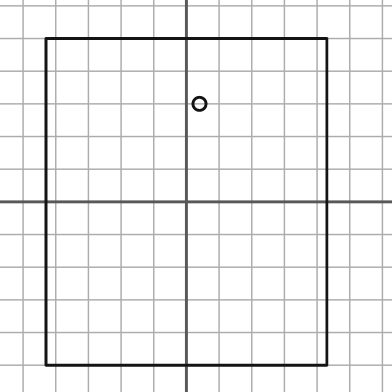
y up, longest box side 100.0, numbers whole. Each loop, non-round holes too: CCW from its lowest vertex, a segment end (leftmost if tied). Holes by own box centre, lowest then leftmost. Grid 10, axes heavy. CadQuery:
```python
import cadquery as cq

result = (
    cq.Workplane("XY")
    .moveTo(-43.0, -50.0)
    .lineTo(43.0, -50.0)
    .lineTo(43.0, 50.0)
    .lineTo(-43.0, 50.0)
    .close()
    .moveTo(4.0, 30.0)
    .circle(2.0)
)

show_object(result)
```